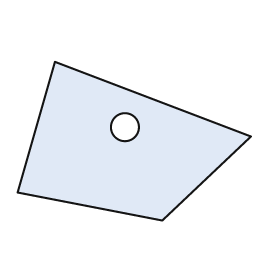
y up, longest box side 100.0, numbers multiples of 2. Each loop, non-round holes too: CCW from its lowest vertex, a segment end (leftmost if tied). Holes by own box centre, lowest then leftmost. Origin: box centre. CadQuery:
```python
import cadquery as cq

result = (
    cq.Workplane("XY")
    .moveTo(12.0, -34.0)
    .lineTo(50.0, 2.0)
    .lineTo(-34.0, 34.0)
    .lineTo(-50.0, -22.0)
    .close()
    .moveTo(-4.0, 6.0)
    .circle(6.0)
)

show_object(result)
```